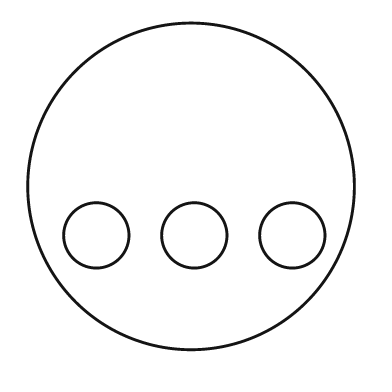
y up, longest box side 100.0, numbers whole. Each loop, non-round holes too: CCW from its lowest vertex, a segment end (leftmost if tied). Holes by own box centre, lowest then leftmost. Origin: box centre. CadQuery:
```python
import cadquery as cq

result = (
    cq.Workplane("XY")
    .moveTo(0.0, 0.0)
    .circle(50.0)
    .moveTo(-29.0, -15.0)
    .circle(10.0)
    .moveTo(1.0, -15.0)
    .circle(10.0)
    .moveTo(31.0, -15.0)
    .circle(10.0)
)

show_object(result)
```